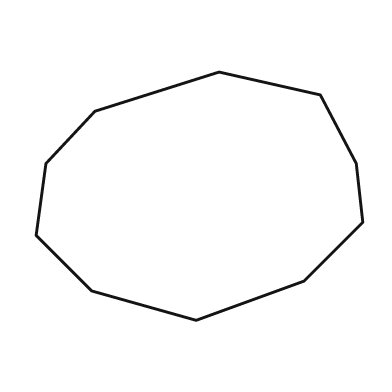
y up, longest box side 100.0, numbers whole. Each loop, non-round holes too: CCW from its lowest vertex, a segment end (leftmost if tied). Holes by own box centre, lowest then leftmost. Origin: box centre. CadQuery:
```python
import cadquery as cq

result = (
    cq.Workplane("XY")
    .moveTo(-1.0, -38.0)
    .lineTo(32.0, -26.0)
    .lineTo(50.0, -8.0)
    .lineTo(48.0, 10.0)
    .lineTo(37.0, 31.0)
    .lineTo(6.0, 38.0)
    .lineTo(-32.0, 26.0)
    .lineTo(-47.0, 10.0)
    .lineTo(-50.0, -12.0)
    .lineTo(-33.0, -29.0)
    .close()
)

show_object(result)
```